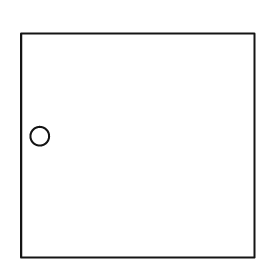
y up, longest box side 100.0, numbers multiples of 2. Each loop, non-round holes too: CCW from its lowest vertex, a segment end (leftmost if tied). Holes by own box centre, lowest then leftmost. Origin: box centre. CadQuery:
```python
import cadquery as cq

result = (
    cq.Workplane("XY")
    .moveTo(-50.0, -48.0)
    .lineTo(50.0, -48.0)
    .lineTo(50.0, 48.0)
    .lineTo(-50.0, 48.0)
    .close()
    .moveTo(-42.0, 4.0)
    .circle(4.0)
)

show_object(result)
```